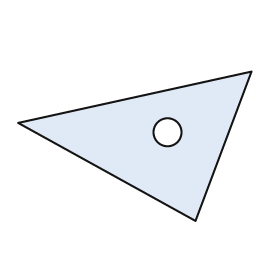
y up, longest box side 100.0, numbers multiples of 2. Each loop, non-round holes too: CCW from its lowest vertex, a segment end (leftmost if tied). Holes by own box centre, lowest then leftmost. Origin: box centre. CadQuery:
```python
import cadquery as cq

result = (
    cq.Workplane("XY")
    .moveTo(26.0, -32.0)
    .lineTo(50.0, 32.0)
    .lineTo(-50.0, 10.0)
    .close()
    .moveTo(14.0, 6.0)
    .circle(6.0)
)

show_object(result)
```